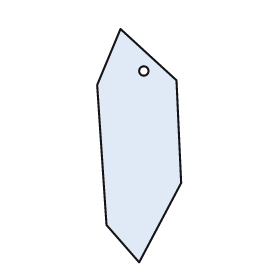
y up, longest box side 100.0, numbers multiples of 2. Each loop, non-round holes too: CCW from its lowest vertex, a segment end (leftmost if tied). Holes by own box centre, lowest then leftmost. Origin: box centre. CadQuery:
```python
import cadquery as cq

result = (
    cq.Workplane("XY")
    .moveTo(0.0, -50.0)
    .lineTo(18.0, -16.0)
    .lineTo(16.0, 28.0)
    .lineTo(-8.0, 50.0)
    .lineTo(-18.0, 26.0)
    .lineTo(-14.0, -34.0)
    .close()
    .moveTo(2.0, 32.0)
    .circle(2.0)
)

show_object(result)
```